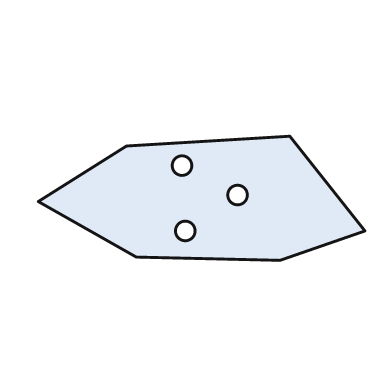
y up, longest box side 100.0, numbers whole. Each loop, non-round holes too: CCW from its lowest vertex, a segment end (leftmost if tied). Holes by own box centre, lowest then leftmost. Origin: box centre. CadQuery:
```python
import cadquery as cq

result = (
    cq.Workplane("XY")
    .moveTo(24.0, -19.0)
    .lineTo(50.0, -10.0)
    .lineTo(27.0, 19.0)
    .lineTo(-23.0, 16.0)
    .lineTo(-50.0, -1.0)
    .lineTo(-20.0, -18.0)
    .close()
    .moveTo(-5.0, -10.0)
    .circle(3.0)
    .moveTo(11.0, 1.0)
    .circle(3.0)
    .moveTo(-6.0, 10.0)
    .circle(3.0)
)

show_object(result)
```